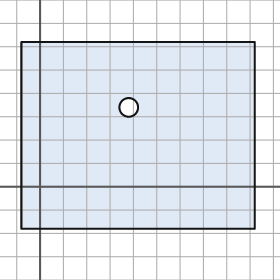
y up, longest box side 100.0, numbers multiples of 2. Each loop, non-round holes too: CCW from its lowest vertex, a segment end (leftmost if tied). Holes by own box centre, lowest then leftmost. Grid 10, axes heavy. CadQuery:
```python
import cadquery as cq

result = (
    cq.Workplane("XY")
    .moveTo(-8.0, -18.0)
    .lineTo(92.0, -18.0)
    .lineTo(92.0, 62.0)
    .lineTo(-8.0, 62.0)
    .close()
    .moveTo(38.0, 34.0)
    .circle(4.0)
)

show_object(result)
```